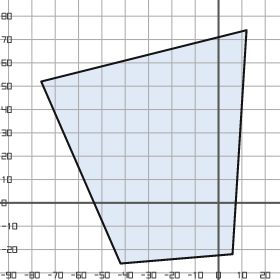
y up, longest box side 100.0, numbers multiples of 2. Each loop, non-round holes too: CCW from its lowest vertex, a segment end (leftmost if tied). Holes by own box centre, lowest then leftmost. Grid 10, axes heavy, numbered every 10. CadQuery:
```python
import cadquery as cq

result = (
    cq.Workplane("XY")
    .moveTo(-42.0, -26.0)
    .lineTo(6.0, -22.0)
    .lineTo(12.0, 74.0)
    .lineTo(-76.0, 52.0)
    .close()
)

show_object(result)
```